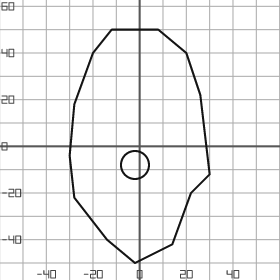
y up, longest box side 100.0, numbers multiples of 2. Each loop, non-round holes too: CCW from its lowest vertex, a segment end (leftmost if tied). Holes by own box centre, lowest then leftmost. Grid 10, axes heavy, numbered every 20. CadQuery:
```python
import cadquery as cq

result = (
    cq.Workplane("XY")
    .moveTo(-2.0, -50.0)
    .lineTo(14.0, -42.0)
    .lineTo(22.0, -20.0)
    .lineTo(30.0, -12.0)
    .lineTo(26.0, 22.0)
    .lineTo(20.0, 40.0)
    .lineTo(8.0, 50.0)
    .lineTo(-12.0, 50.0)
    .lineTo(-20.0, 40.0)
    .lineTo(-28.0, 18.0)
    .lineTo(-30.0, -4.0)
    .lineTo(-28.0, -22.0)
    .lineTo(-14.0, -40.0)
    .close()
    .moveTo(-2.0, -8.0)
    .circle(6.0)
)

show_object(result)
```